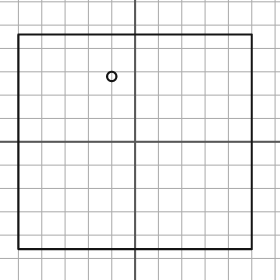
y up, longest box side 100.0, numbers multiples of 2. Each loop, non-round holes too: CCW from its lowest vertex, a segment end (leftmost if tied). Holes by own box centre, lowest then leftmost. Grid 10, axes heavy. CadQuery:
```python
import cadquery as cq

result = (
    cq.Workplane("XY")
    .moveTo(-50.0, -46.0)
    .lineTo(50.0, -46.0)
    .lineTo(50.0, 46.0)
    .lineTo(-50.0, 46.0)
    .close()
    .moveTo(-10.0, 28.0)
    .circle(2.0)
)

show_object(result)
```